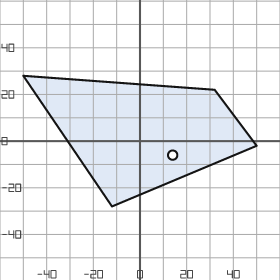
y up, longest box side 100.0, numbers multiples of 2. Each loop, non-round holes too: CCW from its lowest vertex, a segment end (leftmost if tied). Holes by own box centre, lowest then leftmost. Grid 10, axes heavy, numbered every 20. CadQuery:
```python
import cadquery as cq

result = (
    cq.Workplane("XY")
    .moveTo(-12.0, -28.0)
    .lineTo(50.0, -2.0)
    .lineTo(32.0, 22.0)
    .lineTo(-50.0, 28.0)
    .close()
    .moveTo(14.0, -6.0)
    .circle(2.0)
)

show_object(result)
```